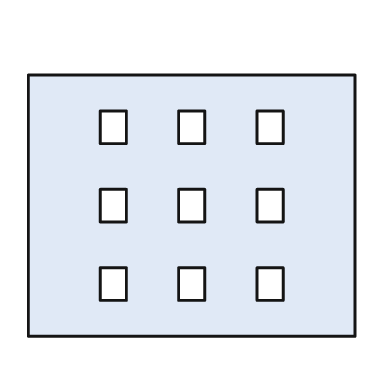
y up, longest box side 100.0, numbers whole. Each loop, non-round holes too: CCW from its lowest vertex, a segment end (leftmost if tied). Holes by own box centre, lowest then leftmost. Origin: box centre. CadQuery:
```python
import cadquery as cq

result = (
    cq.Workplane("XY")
    .moveTo(-50.0, -40.0)
    .lineTo(50.0, -40.0)
    .lineTo(50.0, 40.0)
    .lineTo(-50.0, 40.0)
    .close()
    .moveTo(-28.0, -29.0)
    .lineTo(-20.0, -29.0)
    .lineTo(-20.0, -19.0)
    .lineTo(-28.0, -19.0)
    .close()
    .moveTo(-4.0, -29.0)
    .lineTo(4.0, -29.0)
    .lineTo(4.0, -19.0)
    .lineTo(-4.0, -19.0)
    .close()
    .moveTo(20.0, -29.0)
    .lineTo(28.0, -29.0)
    .lineTo(28.0, -19.0)
    .lineTo(20.0, -19.0)
    .close()
    .moveTo(-28.0, -5.0)
    .lineTo(-20.0, -5.0)
    .lineTo(-20.0, 5.0)
    .lineTo(-28.0, 5.0)
    .close()
    .moveTo(-4.0, -5.0)
    .lineTo(4.0, -5.0)
    .lineTo(4.0, 5.0)
    .lineTo(-4.0, 5.0)
    .close()
    .moveTo(20.0, -5.0)
    .lineTo(28.0, -5.0)
    .lineTo(28.0, 5.0)
    .lineTo(20.0, 5.0)
    .close()
    .moveTo(-28.0, 19.0)
    .lineTo(-20.0, 19.0)
    .lineTo(-20.0, 29.0)
    .lineTo(-28.0, 29.0)
    .close()
    .moveTo(-4.0, 19.0)
    .lineTo(4.0, 19.0)
    .lineTo(4.0, 29.0)
    .lineTo(-4.0, 29.0)
    .close()
    .moveTo(20.0, 19.0)
    .lineTo(28.0, 19.0)
    .lineTo(28.0, 29.0)
    .lineTo(20.0, 29.0)
    .close()
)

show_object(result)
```